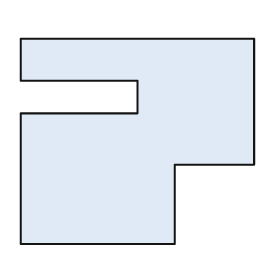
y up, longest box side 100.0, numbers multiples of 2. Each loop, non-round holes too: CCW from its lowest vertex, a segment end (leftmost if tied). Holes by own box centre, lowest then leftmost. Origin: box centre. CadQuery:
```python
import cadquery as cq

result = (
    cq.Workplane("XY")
    .moveTo(-50.0, -44.0)
    .lineTo(16.0, -44.0)
    .lineTo(16.0, -10.0)
    .lineTo(50.0, -10.0)
    .lineTo(50.0, 44.0)
    .lineTo(-50.0, 44.0)
    .lineTo(-50.0, 26.0)
    .lineTo(0.0, 26.0)
    .lineTo(0.0, 12.0)
    .lineTo(-50.0, 12.0)
    .close()
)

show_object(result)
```